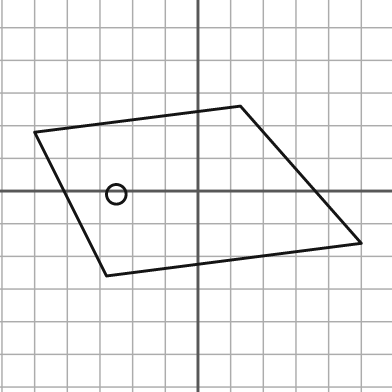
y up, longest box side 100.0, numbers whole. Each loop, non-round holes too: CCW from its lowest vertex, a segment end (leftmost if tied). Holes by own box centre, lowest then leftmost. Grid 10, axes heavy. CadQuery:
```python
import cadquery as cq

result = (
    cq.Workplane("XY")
    .moveTo(-28.0, -26.0)
    .lineTo(50.0, -16.0)
    .lineTo(13.0, 26.0)
    .lineTo(-50.0, 18.0)
    .close()
    .moveTo(-25.0, -1.0)
    .circle(3.0)
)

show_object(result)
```